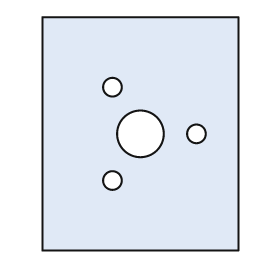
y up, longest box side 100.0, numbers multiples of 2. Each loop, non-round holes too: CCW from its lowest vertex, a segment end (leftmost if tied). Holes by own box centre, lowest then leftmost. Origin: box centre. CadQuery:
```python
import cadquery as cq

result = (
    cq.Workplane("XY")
    .moveTo(-42.0, -50.0)
    .lineTo(42.0, -50.0)
    .lineTo(42.0, 50.0)
    .lineTo(-42.0, 50.0)
    .close()
    .moveTo(-12.0, -20.0)
    .circle(4.0)
    .moveTo(0.0, 0.0)
    .circle(10.0)
    .moveTo(24.0, 0.0)
    .circle(4.0)
    .moveTo(-12.0, 20.0)
    .circle(4.0)
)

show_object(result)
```